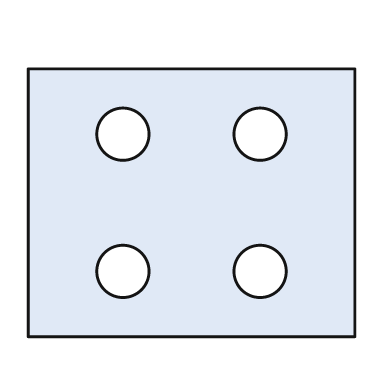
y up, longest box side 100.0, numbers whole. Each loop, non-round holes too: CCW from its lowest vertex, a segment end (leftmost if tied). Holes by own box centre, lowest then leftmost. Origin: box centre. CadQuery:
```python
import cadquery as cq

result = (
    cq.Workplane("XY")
    .moveTo(-50.0, -41.0)
    .lineTo(50.0, -41.0)
    .lineTo(50.0, 41.0)
    .lineTo(-50.0, 41.0)
    .close()
    .moveTo(-21.0, -21.0)
    .circle(8.0)
    .moveTo(21.0, -21.0)
    .circle(8.0)
    .moveTo(-21.0, 21.0)
    .circle(8.0)
    .moveTo(21.0, 21.0)
    .circle(8.0)
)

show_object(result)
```